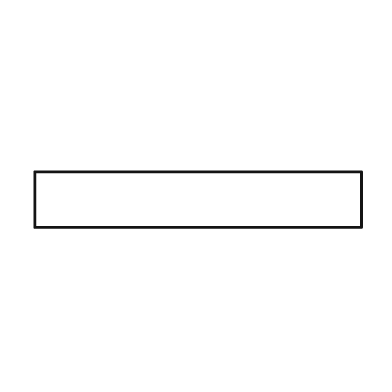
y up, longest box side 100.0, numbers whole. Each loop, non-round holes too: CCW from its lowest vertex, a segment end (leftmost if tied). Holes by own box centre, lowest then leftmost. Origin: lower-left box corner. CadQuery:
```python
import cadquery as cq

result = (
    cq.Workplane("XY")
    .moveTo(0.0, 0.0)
    .lineTo(100.0, 0.0)
    .lineTo(100.0, 17.0)
    .lineTo(0.0, 17.0)
    .close()
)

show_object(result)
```